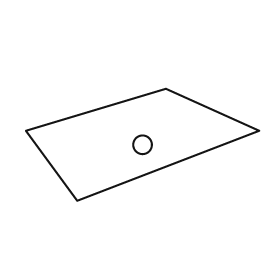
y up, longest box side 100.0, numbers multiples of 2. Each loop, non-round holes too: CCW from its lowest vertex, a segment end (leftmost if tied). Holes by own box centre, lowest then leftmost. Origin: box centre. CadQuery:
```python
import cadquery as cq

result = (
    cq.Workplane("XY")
    .moveTo(-28.0, -24.0)
    .lineTo(50.0, 6.0)
    .lineTo(10.0, 24.0)
    .lineTo(-50.0, 6.0)
    .close()
    .moveTo(0.0, 0.0)
    .circle(4.0)
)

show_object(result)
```